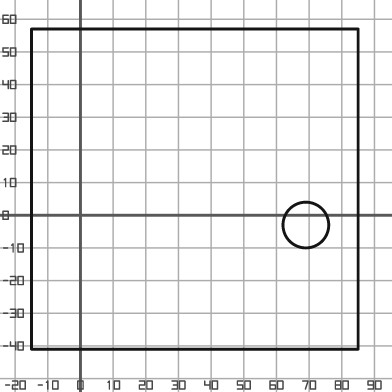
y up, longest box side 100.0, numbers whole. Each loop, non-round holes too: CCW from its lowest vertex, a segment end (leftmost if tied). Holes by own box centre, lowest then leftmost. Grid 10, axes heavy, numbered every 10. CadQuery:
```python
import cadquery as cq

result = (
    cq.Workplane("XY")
    .moveTo(-15.0, -41.0)
    .lineTo(85.0, -41.0)
    .lineTo(85.0, 57.0)
    .lineTo(-15.0, 57.0)
    .close()
    .moveTo(69.0, -3.0)
    .circle(7.0)
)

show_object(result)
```